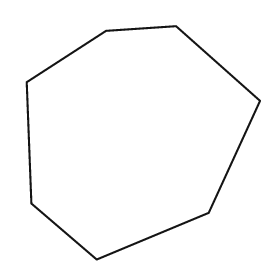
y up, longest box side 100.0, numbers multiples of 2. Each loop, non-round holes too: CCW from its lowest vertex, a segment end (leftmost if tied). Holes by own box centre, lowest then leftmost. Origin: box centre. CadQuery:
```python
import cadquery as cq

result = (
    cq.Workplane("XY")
    .moveTo(-20.0, -50.0)
    .lineTo(28.0, -30.0)
    .lineTo(50.0, 18.0)
    .lineTo(14.0, 50.0)
    .lineTo(-16.0, 48.0)
    .lineTo(-50.0, 26.0)
    .lineTo(-48.0, -26.0)
    .close()
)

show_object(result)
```